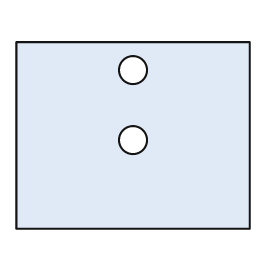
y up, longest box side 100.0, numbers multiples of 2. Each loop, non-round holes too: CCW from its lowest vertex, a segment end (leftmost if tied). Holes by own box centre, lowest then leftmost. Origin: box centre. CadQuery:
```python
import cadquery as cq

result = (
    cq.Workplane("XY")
    .moveTo(-50.0, -40.0)
    .lineTo(50.0, -40.0)
    .lineTo(50.0, 40.0)
    .lineTo(-50.0, 40.0)
    .close()
    .moveTo(0.0, -2.0)
    .circle(6.0)
    .moveTo(0.0, 28.0)
    .circle(6.0)
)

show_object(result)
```